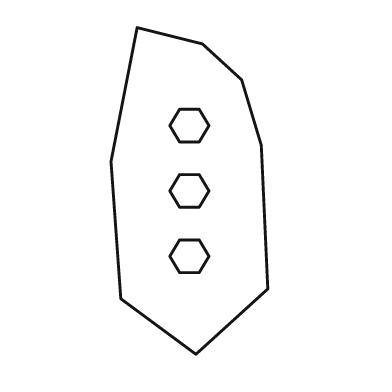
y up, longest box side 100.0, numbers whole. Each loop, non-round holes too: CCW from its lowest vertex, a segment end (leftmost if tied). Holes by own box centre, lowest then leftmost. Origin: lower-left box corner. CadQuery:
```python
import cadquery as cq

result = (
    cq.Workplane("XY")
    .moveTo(26.0, 0.0)
    .lineTo(48.0, 20.0)
    .lineTo(46.0, 64.0)
    .lineTo(40.0, 84.0)
    .lineTo(28.0, 95.0)
    .lineTo(8.0, 100.0)
    .lineTo(0.0, 59.0)
    .lineTo(3.0, 17.0)
    .close()
    .moveTo(21.0, 25.0)
    .lineTo(27.0, 25.0)
    .lineTo(30.0, 30.0)
    .lineTo(27.0, 35.0)
    .lineTo(21.0, 35.0)
    .lineTo(18.0, 30.0)
    .close()
    .moveTo(21.0, 45.0)
    .lineTo(27.0, 45.0)
    .lineTo(30.0, 50.0)
    .lineTo(27.0, 55.0)
    .lineTo(21.0, 55.0)
    .lineTo(18.0, 50.0)
    .close()
    .moveTo(21.0, 65.0)
    .lineTo(27.0, 65.0)
    .lineTo(30.0, 70.0)
    .lineTo(27.0, 75.0)
    .lineTo(21.0, 75.0)
    .lineTo(18.0, 70.0)
    .close()
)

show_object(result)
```